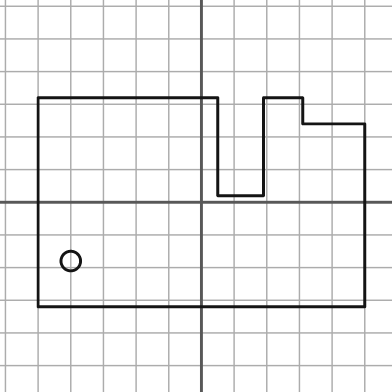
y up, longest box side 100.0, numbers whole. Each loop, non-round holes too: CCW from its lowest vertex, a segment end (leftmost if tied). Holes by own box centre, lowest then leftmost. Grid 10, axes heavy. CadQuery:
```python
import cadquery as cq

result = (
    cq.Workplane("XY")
    .moveTo(-50.0, -32.0)
    .lineTo(50.0, -32.0)
    .lineTo(50.0, 24.0)
    .lineTo(31.0, 24.0)
    .lineTo(31.0, 32.0)
    .lineTo(19.0, 32.0)
    .lineTo(19.0, 2.0)
    .lineTo(5.0, 2.0)
    .lineTo(5.0, 32.0)
    .lineTo(-50.0, 32.0)
    .close()
    .moveTo(-40.0, -18.0)
    .circle(3.0)
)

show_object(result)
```